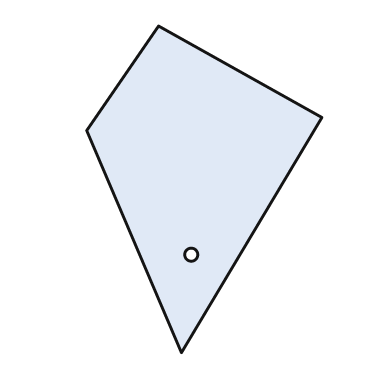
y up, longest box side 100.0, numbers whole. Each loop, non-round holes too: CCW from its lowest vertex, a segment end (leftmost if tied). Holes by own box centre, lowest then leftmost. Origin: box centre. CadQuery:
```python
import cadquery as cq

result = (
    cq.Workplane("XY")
    .moveTo(-7.0, -50.0)
    .lineTo(36.0, 22.0)
    .lineTo(-14.0, 50.0)
    .lineTo(-36.0, 18.0)
    .close()
    .moveTo(-4.0, -20.0)
    .circle(2.0)
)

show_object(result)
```